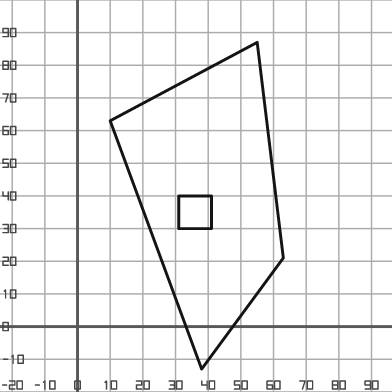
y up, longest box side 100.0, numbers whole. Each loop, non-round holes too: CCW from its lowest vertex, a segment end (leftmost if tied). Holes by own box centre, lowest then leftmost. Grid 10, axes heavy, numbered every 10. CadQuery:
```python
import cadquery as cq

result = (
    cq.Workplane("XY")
    .moveTo(38.0, -13.0)
    .lineTo(63.0, 21.0)
    .lineTo(55.0, 87.0)
    .lineTo(10.0, 63.0)
    .close()
    .moveTo(31.0, 30.0)
    .lineTo(41.0, 30.0)
    .lineTo(41.0, 40.0)
    .lineTo(31.0, 40.0)
    .close()
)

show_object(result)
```